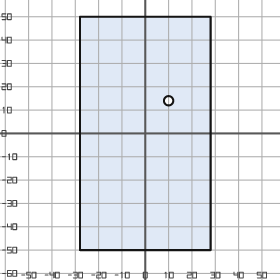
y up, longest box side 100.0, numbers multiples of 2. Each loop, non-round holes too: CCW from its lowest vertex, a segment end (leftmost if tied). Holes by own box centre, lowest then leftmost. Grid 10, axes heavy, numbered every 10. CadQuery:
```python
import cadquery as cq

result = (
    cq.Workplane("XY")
    .moveTo(-28.0, -50.0)
    .lineTo(28.0, -50.0)
    .lineTo(28.0, 50.0)
    .lineTo(-28.0, 50.0)
    .close()
    .moveTo(10.0, 14.0)
    .circle(2.0)
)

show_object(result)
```